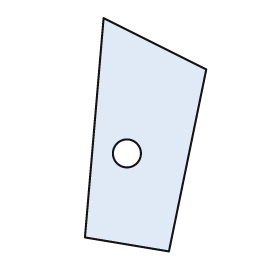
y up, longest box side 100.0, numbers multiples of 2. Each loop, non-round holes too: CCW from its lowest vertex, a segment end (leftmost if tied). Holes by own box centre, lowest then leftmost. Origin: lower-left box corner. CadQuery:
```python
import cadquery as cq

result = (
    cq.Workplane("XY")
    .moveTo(36.0, 0.0)
    .lineTo(52.0, 78.0)
    .lineTo(8.0, 100.0)
    .lineTo(0.0, 6.0)
    .close()
    .moveTo(18.0, 42.0)
    .circle(6.0)
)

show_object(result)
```